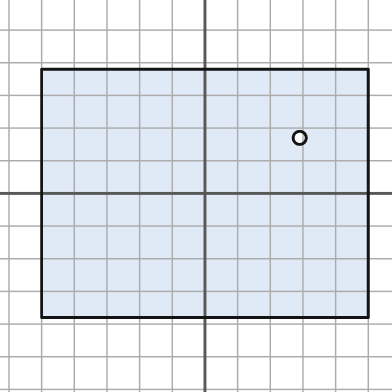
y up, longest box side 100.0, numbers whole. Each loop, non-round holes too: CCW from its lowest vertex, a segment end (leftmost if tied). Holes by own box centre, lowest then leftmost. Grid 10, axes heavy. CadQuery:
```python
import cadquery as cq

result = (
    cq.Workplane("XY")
    .moveTo(-50.0, -38.0)
    .lineTo(50.0, -38.0)
    .lineTo(50.0, 38.0)
    .lineTo(-50.0, 38.0)
    .close()
    .moveTo(29.0, 17.0)
    .circle(2.0)
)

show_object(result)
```